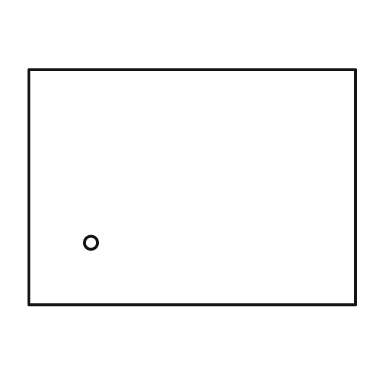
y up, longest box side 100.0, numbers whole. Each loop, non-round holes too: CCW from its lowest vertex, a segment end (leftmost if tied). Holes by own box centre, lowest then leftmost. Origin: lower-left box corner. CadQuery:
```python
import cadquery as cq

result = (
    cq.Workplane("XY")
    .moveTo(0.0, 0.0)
    .lineTo(100.0, 0.0)
    .lineTo(100.0, 72.0)
    .lineTo(0.0, 72.0)
    .close()
    .moveTo(19.0, 19.0)
    .circle(2.0)
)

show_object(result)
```